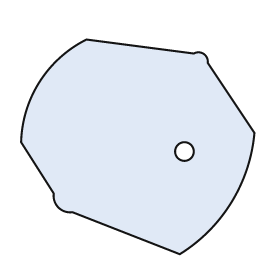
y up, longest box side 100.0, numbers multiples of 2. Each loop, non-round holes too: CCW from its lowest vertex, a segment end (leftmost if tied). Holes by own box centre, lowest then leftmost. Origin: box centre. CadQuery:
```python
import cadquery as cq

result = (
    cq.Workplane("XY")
    .moveTo(18.0, -46.0)
    .threePointArc((40.0, -24.0), (50.0, 6.0))
    .lineTo(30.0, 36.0)
    .threePointArc((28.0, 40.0), (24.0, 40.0))
    .lineTo(-22.0, 46.0)
    .threePointArc((-42.0, 28.0), (-50.0, 2.0))
    .lineTo(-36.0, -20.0)
    .threePointArc((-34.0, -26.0), (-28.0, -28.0))
    .close()
    .moveTo(20.0, -2.0)
    .circle(4.0)
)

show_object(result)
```